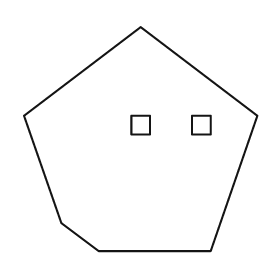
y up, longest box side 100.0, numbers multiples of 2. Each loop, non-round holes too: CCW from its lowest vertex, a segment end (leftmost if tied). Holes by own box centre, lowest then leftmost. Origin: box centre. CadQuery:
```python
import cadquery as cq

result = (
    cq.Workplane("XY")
    .moveTo(-18.0, -48.0)
    .lineTo(30.0, -48.0)
    .lineTo(50.0, 10.0)
    .lineTo(0.0, 48.0)
    .lineTo(-50.0, 10.0)
    .lineTo(-34.0, -36.0)
    .close()
    .moveTo(-4.0, 2.0)
    .lineTo(4.0, 2.0)
    .lineTo(4.0, 10.0)
    .lineTo(-4.0, 10.0)
    .close()
    .moveTo(22.0, 2.0)
    .lineTo(30.0, 2.0)
    .lineTo(30.0, 10.0)
    .lineTo(22.0, 10.0)
    .close()
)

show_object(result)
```